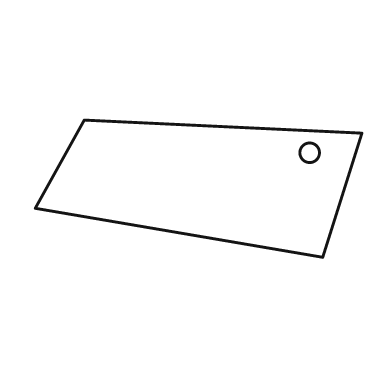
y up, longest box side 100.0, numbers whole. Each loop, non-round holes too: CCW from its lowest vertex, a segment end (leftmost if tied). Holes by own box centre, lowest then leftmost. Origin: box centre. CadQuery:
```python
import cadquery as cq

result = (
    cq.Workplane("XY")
    .moveTo(38.0, -21.0)
    .lineTo(50.0, 17.0)
    .lineTo(-35.0, 21.0)
    .lineTo(-50.0, -6.0)
    .close()
    .moveTo(34.0, 11.0)
    .circle(3.0)
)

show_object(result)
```